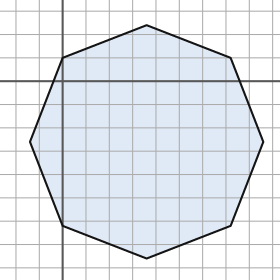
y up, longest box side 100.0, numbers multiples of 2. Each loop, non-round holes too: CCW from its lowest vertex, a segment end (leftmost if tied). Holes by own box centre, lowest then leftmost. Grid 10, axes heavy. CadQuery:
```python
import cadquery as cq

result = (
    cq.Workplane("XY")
    .moveTo(36.0, -76.0)
    .lineTo(72.0, -62.0)
    .lineTo(86.0, -26.0)
    .lineTo(72.0, 10.0)
    .lineTo(36.0, 24.0)
    .lineTo(0.0, 10.0)
    .lineTo(-14.0, -26.0)
    .lineTo(0.0, -62.0)
    .close()
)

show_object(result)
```